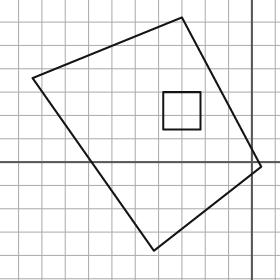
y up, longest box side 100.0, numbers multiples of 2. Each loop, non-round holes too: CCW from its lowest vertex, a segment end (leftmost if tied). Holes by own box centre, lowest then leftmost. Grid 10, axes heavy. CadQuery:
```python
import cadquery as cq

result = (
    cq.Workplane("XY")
    .moveTo(-42.0, -38.0)
    .lineTo(4.0, -2.0)
    .lineTo(-30.0, 62.0)
    .lineTo(-94.0, 36.0)
    .close()
    .moveTo(-38.0, 14.0)
    .lineTo(-22.0, 14.0)
    .lineTo(-22.0, 30.0)
    .lineTo(-38.0, 30.0)
    .close()
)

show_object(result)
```